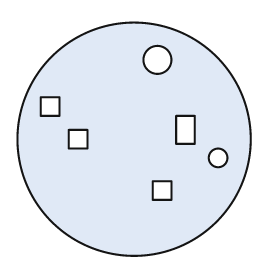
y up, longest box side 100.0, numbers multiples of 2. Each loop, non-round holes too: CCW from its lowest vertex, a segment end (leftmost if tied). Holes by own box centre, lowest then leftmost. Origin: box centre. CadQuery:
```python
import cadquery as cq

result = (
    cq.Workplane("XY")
    .moveTo(0.0, 0.0)
    .circle(50.0)
    .moveTo(8.0, -26.0)
    .lineTo(16.0, -26.0)
    .lineTo(16.0, -18.0)
    .lineTo(8.0, -18.0)
    .close()
    .moveTo(36.0, -8.0)
    .circle(4.0)
    .moveTo(-28.0, -4.0)
    .lineTo(-20.0, -4.0)
    .lineTo(-20.0, 4.0)
    .lineTo(-28.0, 4.0)
    .close()
    .moveTo(18.0, -2.0)
    .lineTo(26.0, -2.0)
    .lineTo(26.0, 10.0)
    .lineTo(18.0, 10.0)
    .close()
    .moveTo(-40.0, 10.0)
    .lineTo(-32.0, 10.0)
    .lineTo(-32.0, 18.0)
    .lineTo(-40.0, 18.0)
    .close()
    .moveTo(10.0, 34.0)
    .circle(6.0)
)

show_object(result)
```